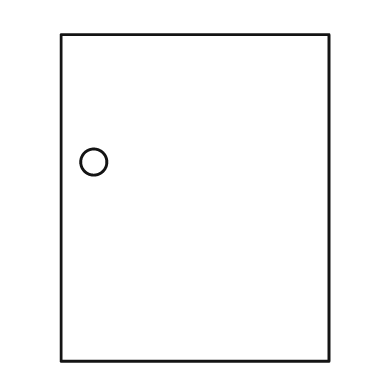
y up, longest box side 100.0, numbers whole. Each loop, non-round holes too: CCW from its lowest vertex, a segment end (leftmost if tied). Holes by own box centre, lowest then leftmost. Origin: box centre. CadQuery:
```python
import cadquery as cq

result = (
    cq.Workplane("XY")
    .moveTo(-41.0, -50.0)
    .lineTo(41.0, -50.0)
    .lineTo(41.0, 50.0)
    .lineTo(-41.0, 50.0)
    .close()
    .moveTo(-31.0, 11.0)
    .circle(4.0)
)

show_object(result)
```